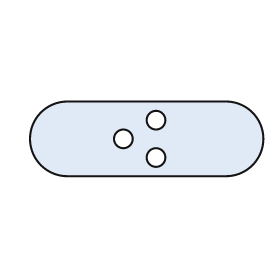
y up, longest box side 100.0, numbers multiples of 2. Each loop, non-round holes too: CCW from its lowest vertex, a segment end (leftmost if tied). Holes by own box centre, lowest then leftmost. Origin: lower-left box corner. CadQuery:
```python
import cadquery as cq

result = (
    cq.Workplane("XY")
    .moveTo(16.0, 0.0)
    .lineTo(84.0, 0.0)
    .threePointArc((100.0, 16.0), (84.0, 32.0))
    .lineTo(16.0, 32.0)
    .threePointArc((0.0, 16.0), (16.0, 0.0))
    .close()
    .moveTo(54.0, 8.0)
    .circle(4.0)
    .moveTo(40.0, 16.0)
    .circle(4.0)
    .moveTo(54.0, 24.0)
    .circle(4.0)
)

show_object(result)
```